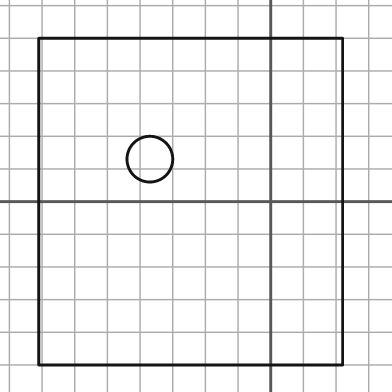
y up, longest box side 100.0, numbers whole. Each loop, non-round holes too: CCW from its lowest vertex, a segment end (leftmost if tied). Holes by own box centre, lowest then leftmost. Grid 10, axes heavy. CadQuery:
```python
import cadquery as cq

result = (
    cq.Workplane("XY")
    .moveTo(-71.0, -50.0)
    .lineTo(22.0, -50.0)
    .lineTo(22.0, 50.0)
    .lineTo(-71.0, 50.0)
    .close()
    .moveTo(-37.0, 13.0)
    .circle(7.0)
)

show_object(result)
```